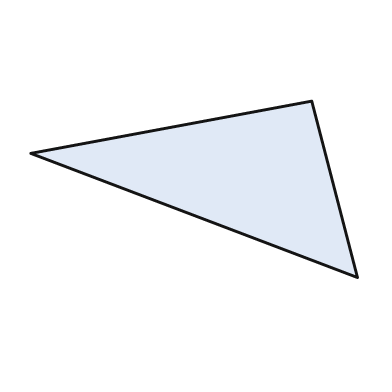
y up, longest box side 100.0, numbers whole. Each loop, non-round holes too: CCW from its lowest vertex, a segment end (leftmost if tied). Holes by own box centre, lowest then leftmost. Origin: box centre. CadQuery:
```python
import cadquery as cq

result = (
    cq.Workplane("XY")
    .moveTo(50.0, -27.0)
    .lineTo(36.0, 27.0)
    .lineTo(-50.0, 11.0)
    .close()
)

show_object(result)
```